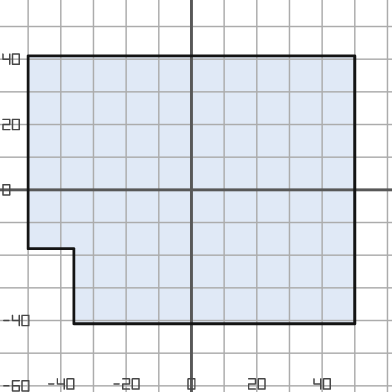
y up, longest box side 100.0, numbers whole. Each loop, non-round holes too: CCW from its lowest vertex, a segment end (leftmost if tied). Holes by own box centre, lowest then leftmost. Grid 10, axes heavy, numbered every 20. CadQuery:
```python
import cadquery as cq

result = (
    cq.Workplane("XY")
    .moveTo(-36.0, -41.0)
    .lineTo(50.0, -41.0)
    .lineTo(50.0, 41.0)
    .lineTo(-50.0, 41.0)
    .lineTo(-50.0, -18.0)
    .lineTo(-36.0, -18.0)
    .close()
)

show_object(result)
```